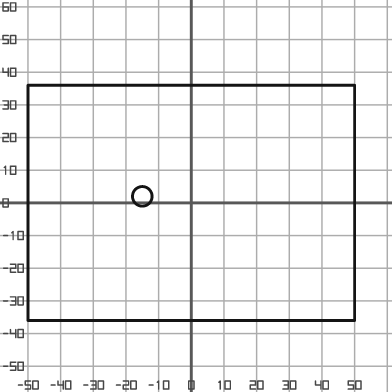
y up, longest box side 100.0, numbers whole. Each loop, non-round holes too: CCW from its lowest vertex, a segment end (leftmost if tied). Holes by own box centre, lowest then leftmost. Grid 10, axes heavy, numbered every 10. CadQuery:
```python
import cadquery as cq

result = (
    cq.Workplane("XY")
    .moveTo(-50.0, -36.0)
    .lineTo(50.0, -36.0)
    .lineTo(50.0, 36.0)
    .lineTo(-50.0, 36.0)
    .close()
    .moveTo(-15.0, 2.0)
    .circle(3.0)
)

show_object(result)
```